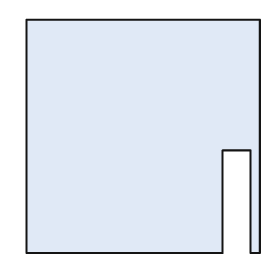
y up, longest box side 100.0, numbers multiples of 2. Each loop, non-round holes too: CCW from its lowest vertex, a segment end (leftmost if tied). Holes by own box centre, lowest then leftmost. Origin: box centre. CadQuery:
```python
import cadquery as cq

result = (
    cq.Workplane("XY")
    .moveTo(-50.0, -50.0)
    .lineTo(34.0, -50.0)
    .lineTo(34.0, -6.0)
    .lineTo(46.0, -6.0)
    .lineTo(46.0, -50.0)
    .lineTo(50.0, -50.0)
    .lineTo(50.0, 50.0)
    .lineTo(-50.0, 50.0)
    .close()
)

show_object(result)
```